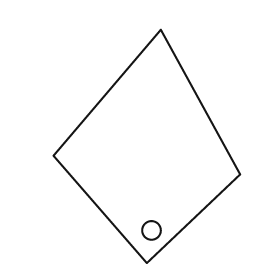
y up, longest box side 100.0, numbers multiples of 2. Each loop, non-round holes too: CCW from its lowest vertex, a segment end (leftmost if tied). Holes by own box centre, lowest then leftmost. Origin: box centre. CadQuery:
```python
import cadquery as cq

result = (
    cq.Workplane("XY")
    .moveTo(0.0, -50.0)
    .lineTo(40.0, -12.0)
    .lineTo(6.0, 50.0)
    .lineTo(-40.0, -4.0)
    .close()
    .moveTo(2.0, -36.0)
    .circle(4.0)
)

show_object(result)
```